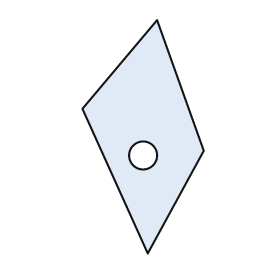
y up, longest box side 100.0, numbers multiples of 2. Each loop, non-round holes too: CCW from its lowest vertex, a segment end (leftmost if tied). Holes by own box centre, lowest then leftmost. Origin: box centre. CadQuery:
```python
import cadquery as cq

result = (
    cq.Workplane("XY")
    .moveTo(2.0, -50.0)
    .lineTo(26.0, -6.0)
    .lineTo(6.0, 50.0)
    .lineTo(-26.0, 12.0)
    .close()
    .moveTo(0.0, -8.0)
    .circle(6.0)
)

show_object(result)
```